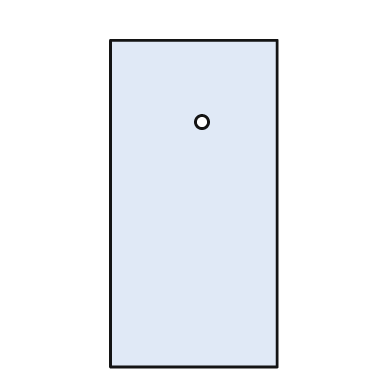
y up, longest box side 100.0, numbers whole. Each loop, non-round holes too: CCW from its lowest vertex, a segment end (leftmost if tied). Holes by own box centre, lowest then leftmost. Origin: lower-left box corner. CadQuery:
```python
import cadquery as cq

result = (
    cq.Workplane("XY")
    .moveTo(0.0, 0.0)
    .lineTo(51.0, 0.0)
    .lineTo(51.0, 100.0)
    .lineTo(0.0, 100.0)
    .close()
    .moveTo(28.0, 75.0)
    .circle(2.0)
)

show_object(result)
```